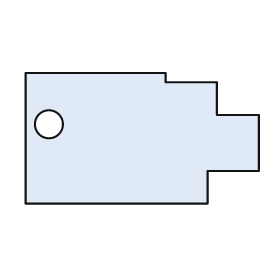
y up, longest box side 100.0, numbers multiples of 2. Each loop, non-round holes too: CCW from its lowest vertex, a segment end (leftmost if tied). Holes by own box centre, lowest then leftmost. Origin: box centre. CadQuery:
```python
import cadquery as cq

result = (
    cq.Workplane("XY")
    .moveTo(-50.0, -28.0)
    .lineTo(28.0, -28.0)
    .lineTo(28.0, -14.0)
    .lineTo(50.0, -14.0)
    .lineTo(50.0, 10.0)
    .lineTo(32.0, 10.0)
    .lineTo(32.0, 24.0)
    .lineTo(10.0, 24.0)
    .lineTo(10.0, 28.0)
    .lineTo(-50.0, 28.0)
    .close()
    .moveTo(-40.0, 6.0)
    .circle(6.0)
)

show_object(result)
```